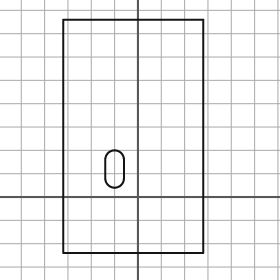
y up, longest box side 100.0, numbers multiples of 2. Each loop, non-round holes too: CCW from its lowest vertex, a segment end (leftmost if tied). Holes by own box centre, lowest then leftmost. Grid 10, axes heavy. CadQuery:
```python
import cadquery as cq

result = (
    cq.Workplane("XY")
    .moveTo(-32.0, -24.0)
    .lineTo(28.0, -24.0)
    .lineTo(28.0, 76.0)
    .lineTo(-32.0, 76.0)
    .close()
    .moveTo(-14.0, 8.0)
    .threePointArc((-10.0, 4.0), (-6.0, 8.0))
    .lineTo(-6.0, 16.0)
    .threePointArc((-10.0, 20.0), (-14.0, 16.0))
    .close()
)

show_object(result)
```